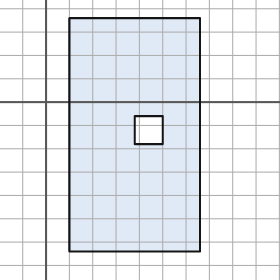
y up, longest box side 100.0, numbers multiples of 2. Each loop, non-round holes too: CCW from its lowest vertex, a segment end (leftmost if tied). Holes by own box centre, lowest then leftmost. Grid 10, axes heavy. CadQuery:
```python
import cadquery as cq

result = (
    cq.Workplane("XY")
    .moveTo(10.0, -64.0)
    .lineTo(66.0, -64.0)
    .lineTo(66.0, 36.0)
    .lineTo(10.0, 36.0)
    .close()
    .moveTo(38.0, -18.0)
    .lineTo(50.0, -18.0)
    .lineTo(50.0, -6.0)
    .lineTo(38.0, -6.0)
    .close()
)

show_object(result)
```